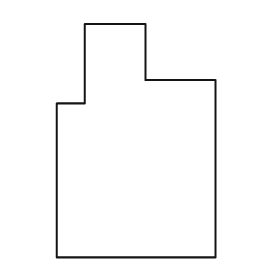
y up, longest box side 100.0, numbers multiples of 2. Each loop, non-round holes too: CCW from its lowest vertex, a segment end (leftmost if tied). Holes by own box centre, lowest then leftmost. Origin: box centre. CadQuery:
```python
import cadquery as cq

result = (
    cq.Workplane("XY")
    .moveTo(-34.0, -50.0)
    .lineTo(34.0, -50.0)
    .lineTo(34.0, 26.0)
    .lineTo(4.0, 26.0)
    .lineTo(4.0, 50.0)
    .lineTo(-22.0, 50.0)
    .lineTo(-22.0, 16.0)
    .lineTo(-34.0, 16.0)
    .close()
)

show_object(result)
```